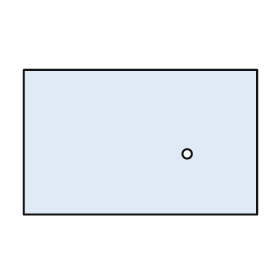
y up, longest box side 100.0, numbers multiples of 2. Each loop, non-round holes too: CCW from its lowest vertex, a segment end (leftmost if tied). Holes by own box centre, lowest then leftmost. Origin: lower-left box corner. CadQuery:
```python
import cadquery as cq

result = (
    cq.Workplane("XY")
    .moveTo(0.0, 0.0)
    .lineTo(100.0, 0.0)
    .lineTo(100.0, 62.0)
    .lineTo(0.0, 62.0)
    .close()
    .moveTo(70.0, 26.0)
    .circle(2.0)
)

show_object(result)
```